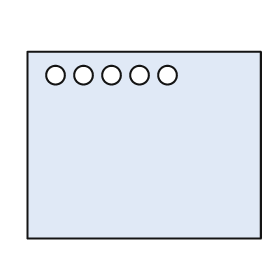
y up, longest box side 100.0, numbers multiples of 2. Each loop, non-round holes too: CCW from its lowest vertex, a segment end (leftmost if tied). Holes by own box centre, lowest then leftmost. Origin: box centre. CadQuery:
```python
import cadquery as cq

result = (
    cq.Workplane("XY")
    .moveTo(-50.0, -40.0)
    .lineTo(50.0, -40.0)
    .lineTo(50.0, 40.0)
    .lineTo(-50.0, 40.0)
    .close()
    .moveTo(-38.0, 30.0)
    .circle(4.0)
    .moveTo(-26.0, 30.0)
    .circle(4.0)
    .moveTo(-14.0, 30.0)
    .circle(4.0)
    .moveTo(-2.0, 30.0)
    .circle(4.0)
    .moveTo(10.0, 30.0)
    .circle(4.0)
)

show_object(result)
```